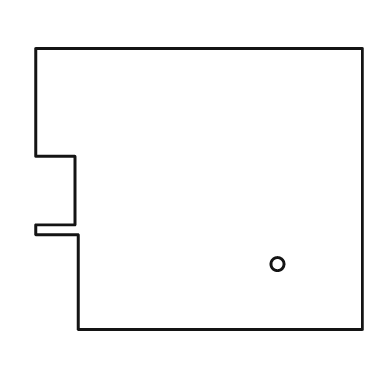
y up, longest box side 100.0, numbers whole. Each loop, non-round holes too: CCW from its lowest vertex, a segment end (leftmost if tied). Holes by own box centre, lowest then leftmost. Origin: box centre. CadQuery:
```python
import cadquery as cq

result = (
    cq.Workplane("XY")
    .moveTo(-37.0, -43.0)
    .lineTo(50.0, -43.0)
    .lineTo(50.0, 43.0)
    .lineTo(-50.0, 43.0)
    .lineTo(-50.0, 10.0)
    .lineTo(-38.0, 10.0)
    .lineTo(-38.0, -11.0)
    .lineTo(-50.0, -11.0)
    .lineTo(-50.0, -14.0)
    .lineTo(-37.0, -14.0)
    .close()
    .moveTo(24.0, -23.0)
    .circle(2.0)
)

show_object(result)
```